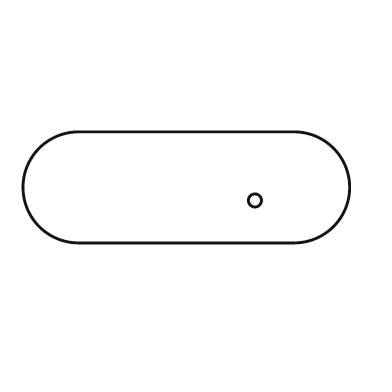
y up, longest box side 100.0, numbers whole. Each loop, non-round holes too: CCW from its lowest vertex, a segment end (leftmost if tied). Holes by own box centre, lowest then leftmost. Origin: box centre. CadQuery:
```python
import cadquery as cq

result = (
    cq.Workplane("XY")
    .moveTo(-33.0, -17.0)
    .lineTo(33.0, -17.0)
    .threePointArc((50.0, 0.0), (33.0, 17.0))
    .lineTo(-33.0, 17.0)
    .threePointArc((-50.0, 0.0), (-33.0, -17.0))
    .close()
    .moveTo(21.0, -4.0)
    .circle(2.0)
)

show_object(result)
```